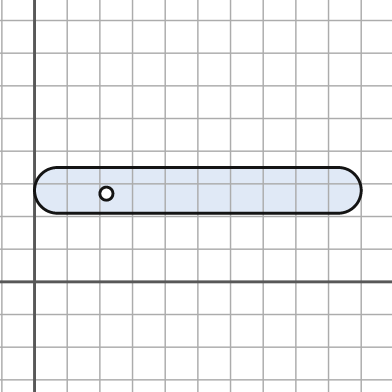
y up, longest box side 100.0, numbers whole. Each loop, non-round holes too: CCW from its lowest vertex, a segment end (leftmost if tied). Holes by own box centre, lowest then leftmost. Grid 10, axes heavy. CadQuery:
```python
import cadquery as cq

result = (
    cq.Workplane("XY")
    .moveTo(7.0, 21.0)
    .lineTo(93.0, 21.0)
    .threePointArc((100.0, 28.0), (93.0, 35.0))
    .lineTo(7.0, 35.0)
    .threePointArc((0.0, 28.0), (7.0, 21.0))
    .close()
    .moveTo(22.0, 27.0)
    .circle(2.0)
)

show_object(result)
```